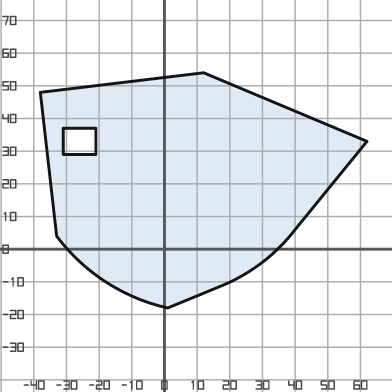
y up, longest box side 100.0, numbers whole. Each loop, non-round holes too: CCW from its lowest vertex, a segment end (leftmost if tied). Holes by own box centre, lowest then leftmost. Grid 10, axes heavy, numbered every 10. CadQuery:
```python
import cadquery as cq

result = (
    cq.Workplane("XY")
    .moveTo(1.0, -18.0)
    .lineTo(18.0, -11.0)
    .threePointArc((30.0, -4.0), (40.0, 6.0))
    .lineTo(62.0, 33.0)
    .lineTo(12.0, 54.0)
    .lineTo(-38.0, 48.0)
    .lineTo(-33.0, 4.0)
    .threePointArc((-18.0, -10.0), (1.0, -18.0))
    .close()
    .moveTo(-31.0, 29.0)
    .lineTo(-21.0, 29.0)
    .lineTo(-21.0, 37.0)
    .lineTo(-31.0, 37.0)
    .close()
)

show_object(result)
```